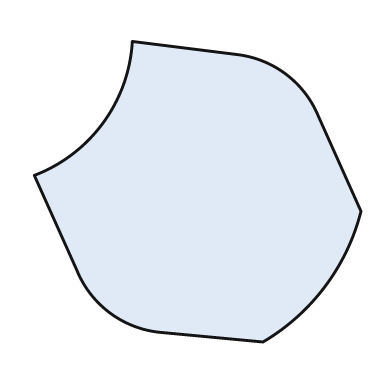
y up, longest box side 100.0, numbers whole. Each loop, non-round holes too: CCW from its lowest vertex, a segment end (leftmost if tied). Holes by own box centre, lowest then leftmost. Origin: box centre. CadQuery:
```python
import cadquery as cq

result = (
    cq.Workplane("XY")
    .moveTo(20.0, -46.0)
    .threePointArc((39.0, -29.0), (50.0, -6.0))
    .lineTo(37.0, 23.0)
    .threePointArc((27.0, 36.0), (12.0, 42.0))
    .lineTo(-20.0, 46.0)
    .threePointArc((-29.0, 21.0), (-50.0, 5.0))
    .lineTo(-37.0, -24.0)
    .threePointArc((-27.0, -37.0), (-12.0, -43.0))
    .close()
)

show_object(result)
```